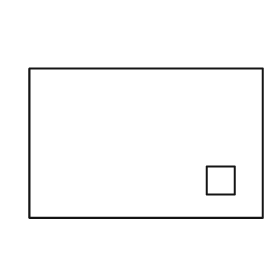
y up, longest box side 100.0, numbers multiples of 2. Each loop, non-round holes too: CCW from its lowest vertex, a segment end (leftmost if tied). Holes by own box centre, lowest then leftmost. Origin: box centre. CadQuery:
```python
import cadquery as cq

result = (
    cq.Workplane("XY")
    .moveTo(-50.0, -32.0)
    .lineTo(50.0, -32.0)
    .lineTo(50.0, 32.0)
    .lineTo(-50.0, 32.0)
    .close()
    .moveTo(26.0, -22.0)
    .lineTo(38.0, -22.0)
    .lineTo(38.0, -10.0)
    .lineTo(26.0, -10.0)
    .close()
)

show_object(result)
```